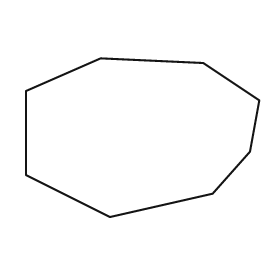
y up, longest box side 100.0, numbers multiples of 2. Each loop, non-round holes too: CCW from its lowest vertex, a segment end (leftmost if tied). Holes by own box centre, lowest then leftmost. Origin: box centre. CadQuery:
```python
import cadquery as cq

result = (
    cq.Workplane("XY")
    .moveTo(-14.0, -34.0)
    .lineTo(30.0, -24.0)
    .lineTo(46.0, -6.0)
    .lineTo(50.0, 16.0)
    .lineTo(26.0, 32.0)
    .lineTo(-18.0, 34.0)
    .lineTo(-50.0, 20.0)
    .lineTo(-50.0, -16.0)
    .close()
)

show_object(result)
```